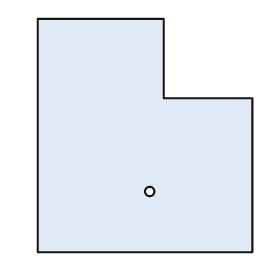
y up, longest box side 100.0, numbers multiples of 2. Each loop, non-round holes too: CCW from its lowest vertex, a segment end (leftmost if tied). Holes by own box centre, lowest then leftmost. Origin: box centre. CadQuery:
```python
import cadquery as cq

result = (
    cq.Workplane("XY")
    .moveTo(-46.0, -50.0)
    .lineTo(46.0, -50.0)
    .lineTo(46.0, 16.0)
    .lineTo(8.0, 16.0)
    .lineTo(8.0, 50.0)
    .lineTo(-46.0, 50.0)
    .close()
    .moveTo(2.0, -24.0)
    .circle(2.0)
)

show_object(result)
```